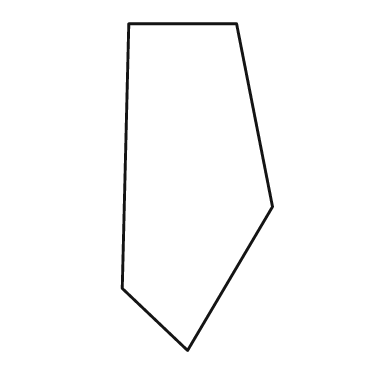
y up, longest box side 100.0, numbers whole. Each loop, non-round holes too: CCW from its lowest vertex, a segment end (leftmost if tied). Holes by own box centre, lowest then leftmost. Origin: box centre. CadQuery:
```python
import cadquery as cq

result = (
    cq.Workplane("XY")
    .moveTo(-3.0, -50.0)
    .lineTo(23.0, -6.0)
    .lineTo(12.0, 50.0)
    .lineTo(-21.0, 50.0)
    .lineTo(-23.0, -31.0)
    .close()
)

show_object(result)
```